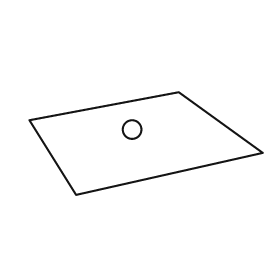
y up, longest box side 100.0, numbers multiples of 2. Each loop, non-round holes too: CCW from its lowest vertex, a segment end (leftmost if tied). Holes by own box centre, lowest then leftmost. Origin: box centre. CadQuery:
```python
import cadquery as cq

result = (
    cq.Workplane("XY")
    .moveTo(-30.0, -22.0)
    .lineTo(50.0, -4.0)
    .lineTo(14.0, 22.0)
    .lineTo(-50.0, 10.0)
    .close()
    .moveTo(-6.0, 6.0)
    .circle(4.0)
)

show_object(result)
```